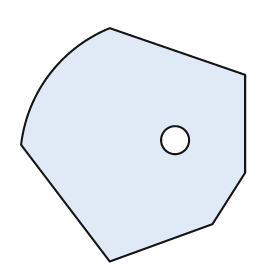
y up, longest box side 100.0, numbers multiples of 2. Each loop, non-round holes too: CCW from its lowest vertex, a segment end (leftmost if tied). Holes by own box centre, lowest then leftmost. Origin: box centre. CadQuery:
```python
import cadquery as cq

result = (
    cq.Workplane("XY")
    .moveTo(-10.0, -50.0)
    .lineTo(34.0, -34.0)
    .lineTo(48.0, -12.0)
    .lineTo(48.0, 30.0)
    .lineTo(-10.0, 50.0)
    .threePointArc((-36.0, 30.0), (-48.0, 0.0))
    .close()
    .moveTo(18.0, 2.0)
    .circle(6.0)
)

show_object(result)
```